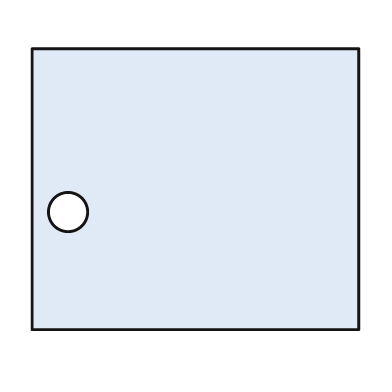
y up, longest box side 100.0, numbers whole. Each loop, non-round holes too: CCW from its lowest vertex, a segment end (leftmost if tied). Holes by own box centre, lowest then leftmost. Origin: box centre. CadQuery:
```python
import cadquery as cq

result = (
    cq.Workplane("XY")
    .moveTo(-50.0, -43.0)
    .lineTo(50.0, -43.0)
    .lineTo(50.0, 43.0)
    .lineTo(-50.0, 43.0)
    .close()
    .moveTo(-39.0, -7.0)
    .circle(6.0)
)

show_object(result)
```